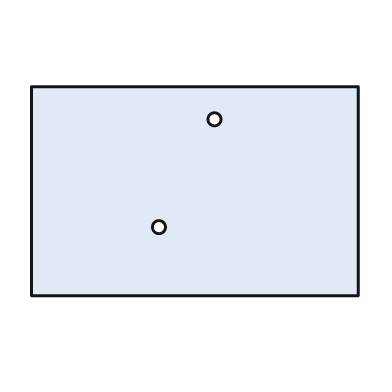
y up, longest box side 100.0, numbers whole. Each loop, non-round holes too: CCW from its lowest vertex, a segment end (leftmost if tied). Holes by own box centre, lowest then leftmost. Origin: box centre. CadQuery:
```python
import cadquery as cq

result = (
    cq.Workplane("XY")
    .moveTo(-50.0, -32.0)
    .lineTo(50.0, -32.0)
    .lineTo(50.0, 32.0)
    .lineTo(-50.0, 32.0)
    .close()
    .moveTo(-11.0, -11.0)
    .circle(2.0)
    .moveTo(6.0, 22.0)
    .circle(2.0)
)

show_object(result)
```